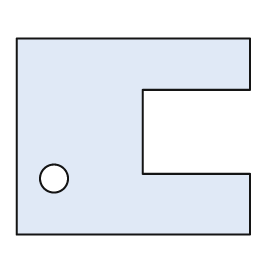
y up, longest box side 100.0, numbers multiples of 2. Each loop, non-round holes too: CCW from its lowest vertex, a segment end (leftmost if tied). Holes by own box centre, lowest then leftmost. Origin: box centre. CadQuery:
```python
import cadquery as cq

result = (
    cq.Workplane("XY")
    .moveTo(-50.0, -42.0)
    .lineTo(50.0, -42.0)
    .lineTo(50.0, -16.0)
    .lineTo(4.0, -16.0)
    .lineTo(4.0, 20.0)
    .lineTo(50.0, 20.0)
    .lineTo(50.0, 42.0)
    .lineTo(-50.0, 42.0)
    .close()
    .moveTo(-34.0, -18.0)
    .circle(6.0)
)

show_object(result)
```